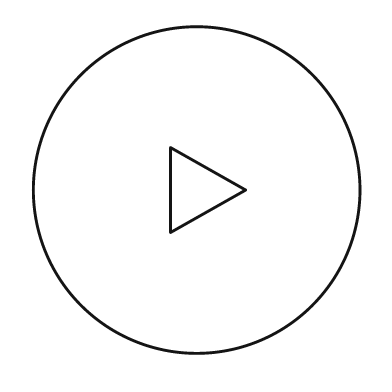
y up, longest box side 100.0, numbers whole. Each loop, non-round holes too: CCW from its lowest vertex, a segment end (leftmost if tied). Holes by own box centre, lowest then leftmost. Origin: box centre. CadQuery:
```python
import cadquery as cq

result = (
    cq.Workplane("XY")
    .moveTo(0.0, 0.0)
    .circle(50.0)
    .moveTo(-8.0, -13.0)
    .lineTo(15.0, 0.0)
    .lineTo(-8.0, 13.0)
    .close()
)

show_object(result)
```